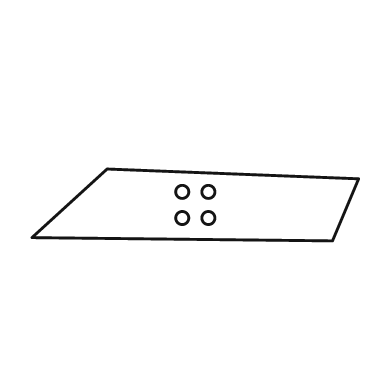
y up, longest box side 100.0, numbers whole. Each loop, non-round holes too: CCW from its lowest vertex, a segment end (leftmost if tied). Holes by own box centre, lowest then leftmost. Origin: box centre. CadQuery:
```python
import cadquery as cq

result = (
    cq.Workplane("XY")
    .moveTo(42.0, -11.0)
    .lineTo(50.0, 8.0)
    .lineTo(-27.0, 11.0)
    .lineTo(-50.0, -10.0)
    .close()
    .moveTo(-4.0, -4.0)
    .circle(2.0)
    .moveTo(4.0, -4.0)
    .circle(2.0)
    .moveTo(-4.0, 4.0)
    .circle(2.0)
    .moveTo(4.0, 4.0)
    .circle(2.0)
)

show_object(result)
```